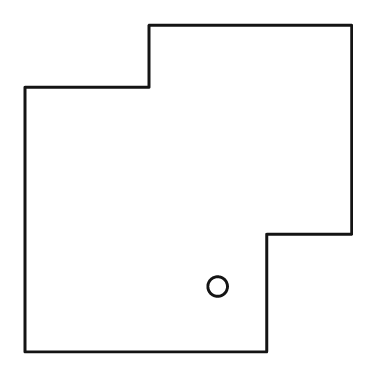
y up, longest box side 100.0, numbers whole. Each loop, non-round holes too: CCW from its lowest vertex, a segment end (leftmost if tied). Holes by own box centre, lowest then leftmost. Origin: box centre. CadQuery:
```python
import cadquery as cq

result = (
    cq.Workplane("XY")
    .moveTo(-50.0, -50.0)
    .lineTo(24.0, -50.0)
    .lineTo(24.0, -14.0)
    .lineTo(50.0, -14.0)
    .lineTo(50.0, 50.0)
    .lineTo(-12.0, 50.0)
    .lineTo(-12.0, 31.0)
    .lineTo(-50.0, 31.0)
    .close()
    .moveTo(9.0, -30.0)
    .circle(3.0)
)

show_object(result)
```